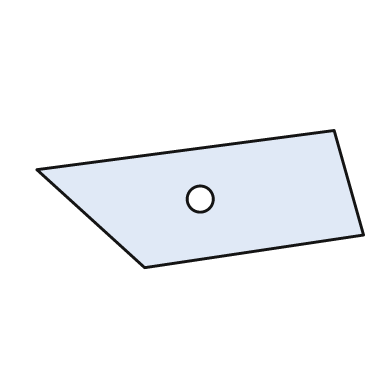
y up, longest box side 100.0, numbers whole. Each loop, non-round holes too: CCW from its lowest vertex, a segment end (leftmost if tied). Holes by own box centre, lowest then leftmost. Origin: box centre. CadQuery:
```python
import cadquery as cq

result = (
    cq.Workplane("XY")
    .moveTo(-17.0, -21.0)
    .lineTo(50.0, -11.0)
    .lineTo(41.0, 21.0)
    .lineTo(-50.0, 9.0)
    .close()
    .moveTo(0.0, 0.0)
    .circle(4.0)
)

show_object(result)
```